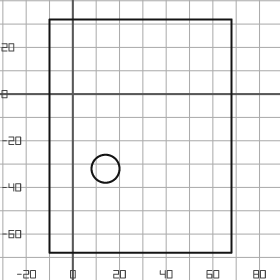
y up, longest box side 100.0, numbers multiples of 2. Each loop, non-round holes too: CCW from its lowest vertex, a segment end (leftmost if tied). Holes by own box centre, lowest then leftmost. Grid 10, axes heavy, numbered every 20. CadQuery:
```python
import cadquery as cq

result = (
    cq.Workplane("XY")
    .moveTo(-10.0, -68.0)
    .lineTo(68.0, -68.0)
    .lineTo(68.0, 32.0)
    .lineTo(-10.0, 32.0)
    .close()
    .moveTo(14.0, -32.0)
    .circle(6.0)
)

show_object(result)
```